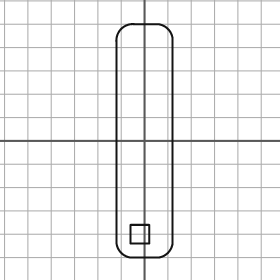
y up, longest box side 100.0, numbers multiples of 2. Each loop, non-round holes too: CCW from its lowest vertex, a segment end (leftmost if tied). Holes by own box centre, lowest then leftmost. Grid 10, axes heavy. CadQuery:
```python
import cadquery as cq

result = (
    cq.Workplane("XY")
    .moveTo(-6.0, -50.0)
    .lineTo(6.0, -50.0)
    .threePointArc((10.0, -48.0), (12.0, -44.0))
    .lineTo(12.0, 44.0)
    .threePointArc((10.0, 48.0), (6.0, 50.0))
    .lineTo(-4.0, 50.0)
    .threePointArc((-10.0, 48.0), (-12.0, 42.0))
    .lineTo(-12.0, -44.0)
    .threePointArc((-10.0, -48.0), (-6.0, -50.0))
    .close()
    .moveTo(-6.0, -44.0)
    .lineTo(2.0, -44.0)
    .lineTo(2.0, -36.0)
    .lineTo(-6.0, -36.0)
    .close()
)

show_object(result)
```